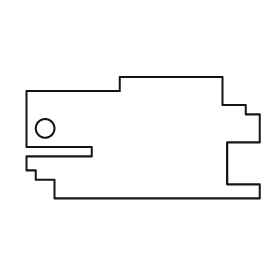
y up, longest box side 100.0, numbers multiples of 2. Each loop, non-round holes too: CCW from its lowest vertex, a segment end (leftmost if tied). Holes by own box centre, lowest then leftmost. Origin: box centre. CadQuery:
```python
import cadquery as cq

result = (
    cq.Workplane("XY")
    .moveTo(-38.0, -26.0)
    .lineTo(50.0, -26.0)
    .lineTo(50.0, -20.0)
    .lineTo(36.0, -20.0)
    .lineTo(36.0, -2.0)
    .lineTo(50.0, -2.0)
    .lineTo(50.0, 10.0)
    .lineTo(44.0, 10.0)
    .lineTo(44.0, 14.0)
    .lineTo(34.0, 14.0)
    .lineTo(34.0, 26.0)
    .lineTo(-10.0, 26.0)
    .lineTo(-10.0, 20.0)
    .lineTo(-50.0, 20.0)
    .lineTo(-50.0, -4.0)
    .lineTo(-22.0, -4.0)
    .lineTo(-22.0, -8.0)
    .lineTo(-50.0, -8.0)
    .lineTo(-50.0, -14.0)
    .lineTo(-46.0, -14.0)
    .lineTo(-46.0, -18.0)
    .lineTo(-38.0, -18.0)
    .close()
    .moveTo(-42.0, 4.0)
    .circle(4.0)
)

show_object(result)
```